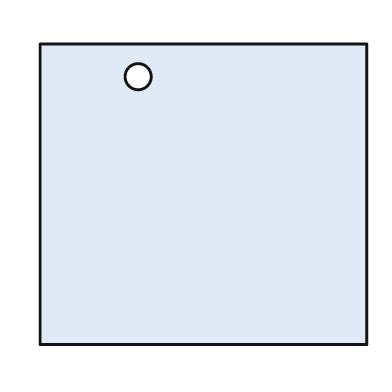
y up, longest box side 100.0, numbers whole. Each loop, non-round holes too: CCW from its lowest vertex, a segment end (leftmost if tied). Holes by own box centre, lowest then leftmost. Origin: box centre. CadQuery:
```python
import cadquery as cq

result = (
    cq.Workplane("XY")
    .moveTo(-50.0, -46.0)
    .lineTo(50.0, -46.0)
    .lineTo(50.0, 46.0)
    .lineTo(-50.0, 46.0)
    .close()
    .moveTo(-20.0, 36.0)
    .circle(4.0)
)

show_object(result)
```